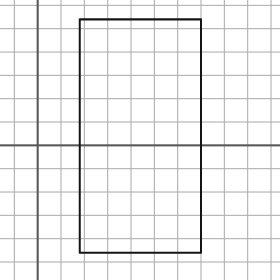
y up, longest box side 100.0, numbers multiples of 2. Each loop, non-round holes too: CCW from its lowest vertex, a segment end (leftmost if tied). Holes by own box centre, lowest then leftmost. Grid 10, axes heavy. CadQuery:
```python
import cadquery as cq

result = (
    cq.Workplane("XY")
    .moveTo(18.0, -46.0)
    .lineTo(70.0, -46.0)
    .lineTo(70.0, 54.0)
    .lineTo(18.0, 54.0)
    .close()
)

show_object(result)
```